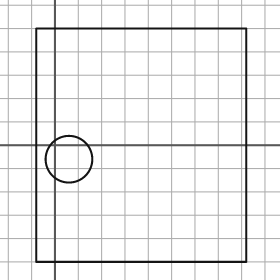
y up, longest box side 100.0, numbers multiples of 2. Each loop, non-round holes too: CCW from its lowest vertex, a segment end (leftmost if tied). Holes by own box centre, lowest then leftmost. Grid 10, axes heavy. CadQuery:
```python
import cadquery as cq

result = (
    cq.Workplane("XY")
    .moveTo(-8.0, -50.0)
    .lineTo(82.0, -50.0)
    .lineTo(82.0, 50.0)
    .lineTo(-8.0, 50.0)
    .close()
    .moveTo(6.0, -6.0)
    .circle(10.0)
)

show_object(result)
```